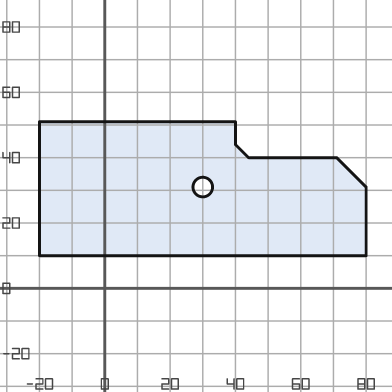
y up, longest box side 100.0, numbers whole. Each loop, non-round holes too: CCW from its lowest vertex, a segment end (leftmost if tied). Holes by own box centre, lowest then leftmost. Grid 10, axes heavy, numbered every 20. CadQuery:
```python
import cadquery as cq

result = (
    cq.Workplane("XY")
    .moveTo(-20.0, 10.0)
    .lineTo(80.0, 10.0)
    .lineTo(80.0, 31.0)
    .lineTo(71.0, 40.0)
    .lineTo(44.0, 40.0)
    .lineTo(40.0, 44.0)
    .lineTo(40.0, 51.0)
    .lineTo(-20.0, 51.0)
    .close()
    .moveTo(30.0, 31.0)
    .circle(3.0)
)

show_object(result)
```